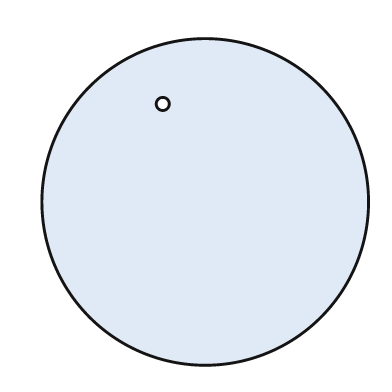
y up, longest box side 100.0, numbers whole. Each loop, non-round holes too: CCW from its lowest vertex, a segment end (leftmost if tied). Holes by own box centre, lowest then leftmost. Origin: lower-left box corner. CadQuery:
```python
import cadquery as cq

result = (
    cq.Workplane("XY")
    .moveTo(50.0, 50.0)
    .circle(50.0)
    .moveTo(37.0, 80.0)
    .circle(2.0)
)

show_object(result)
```